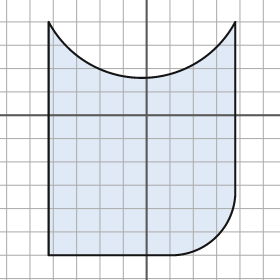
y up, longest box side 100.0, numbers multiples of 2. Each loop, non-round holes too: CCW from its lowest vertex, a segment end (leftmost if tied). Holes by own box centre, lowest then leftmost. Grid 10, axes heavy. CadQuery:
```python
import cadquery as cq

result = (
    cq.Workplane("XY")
    .moveTo(-42.0, -60.0)
    .lineTo(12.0, -60.0)
    .threePointArc((30.0, -52.0), (38.0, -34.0))
    .lineTo(38.0, 40.0)
    .threePointArc((-2.0, 16.0), (-42.0, 40.0))
    .close()
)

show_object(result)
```